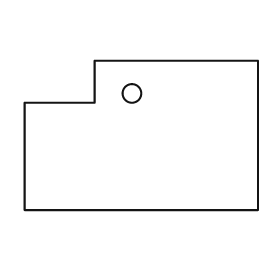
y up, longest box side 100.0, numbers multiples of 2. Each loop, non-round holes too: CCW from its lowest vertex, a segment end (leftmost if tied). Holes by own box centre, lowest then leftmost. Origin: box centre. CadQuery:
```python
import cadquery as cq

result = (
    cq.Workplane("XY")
    .moveTo(-50.0, -32.0)
    .lineTo(50.0, -32.0)
    .lineTo(50.0, 32.0)
    .lineTo(-20.0, 32.0)
    .lineTo(-20.0, 14.0)
    .lineTo(-50.0, 14.0)
    .close()
    .moveTo(-4.0, 18.0)
    .circle(4.0)
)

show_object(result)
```